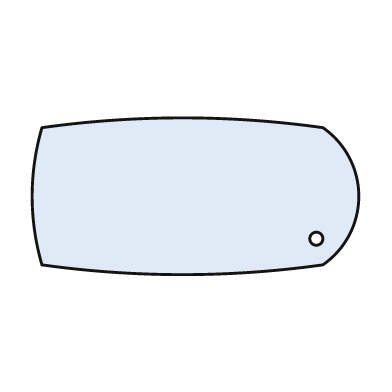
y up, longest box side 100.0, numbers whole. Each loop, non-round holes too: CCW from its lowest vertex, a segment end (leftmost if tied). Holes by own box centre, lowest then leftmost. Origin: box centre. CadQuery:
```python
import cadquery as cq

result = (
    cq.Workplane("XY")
    .moveTo(-47.0, -21.0)
    .threePointArc((-4.0, -24.0), (39.0, -21.0))
    .threePointArc((50.0, 0.0), (39.0, 21.0))
    .threePointArc((-4.0, 24.0), (-47.0, 21.0))
    .threePointArc((-50.0, 0.0), (-47.0, -21.0))
    .close()
    .moveTo(37.0, -13.0)
    .circle(2.0)
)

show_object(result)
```